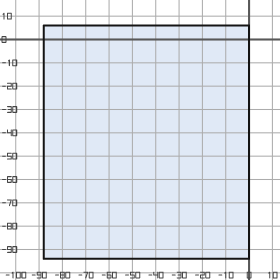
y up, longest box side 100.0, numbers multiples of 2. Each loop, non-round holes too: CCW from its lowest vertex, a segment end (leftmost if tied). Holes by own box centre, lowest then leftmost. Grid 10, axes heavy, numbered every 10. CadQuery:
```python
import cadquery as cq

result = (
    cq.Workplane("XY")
    .moveTo(-88.0, -94.0)
    .lineTo(0.0, -94.0)
    .lineTo(0.0, 6.0)
    .lineTo(-88.0, 6.0)
    .close()
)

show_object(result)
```